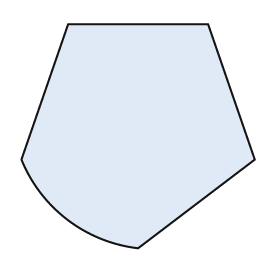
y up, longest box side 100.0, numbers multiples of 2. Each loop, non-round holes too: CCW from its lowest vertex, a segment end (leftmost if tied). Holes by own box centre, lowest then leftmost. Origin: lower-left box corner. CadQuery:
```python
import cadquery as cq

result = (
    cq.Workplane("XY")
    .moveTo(50.0, 0.0)
    .lineTo(100.0, 38.0)
    .lineTo(80.0, 96.0)
    .lineTo(20.0, 96.0)
    .lineTo(0.0, 38.0)
    .threePointArc((20.0, 12.0), (50.0, 0.0))
    .close()
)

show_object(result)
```